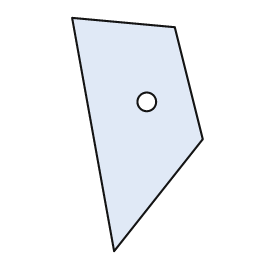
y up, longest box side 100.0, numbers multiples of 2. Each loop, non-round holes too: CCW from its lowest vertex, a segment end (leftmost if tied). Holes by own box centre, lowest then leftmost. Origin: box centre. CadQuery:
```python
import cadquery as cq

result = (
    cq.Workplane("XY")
    .moveTo(-10.0, -50.0)
    .lineTo(28.0, -2.0)
    .lineTo(16.0, 46.0)
    .lineTo(-28.0, 50.0)
    .close()
    .moveTo(4.0, 14.0)
    .circle(4.0)
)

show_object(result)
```